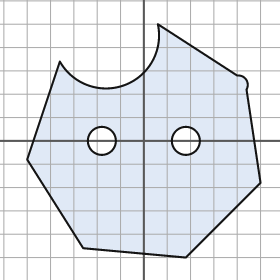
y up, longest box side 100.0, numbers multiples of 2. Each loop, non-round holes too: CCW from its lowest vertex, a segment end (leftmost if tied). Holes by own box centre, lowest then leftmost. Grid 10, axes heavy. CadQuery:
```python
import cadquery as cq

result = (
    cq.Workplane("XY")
    .moveTo(18.0, -50.0)
    .lineTo(50.0, -18.0)
    .lineTo(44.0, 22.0)
    .threePointArc((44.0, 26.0), (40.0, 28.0))
    .lineTo(6.0, 50.0)
    .threePointArc((-8.0, 24.0), (-36.0, 34.0))
    .lineTo(-50.0, -8.0)
    .lineTo(-26.0, -46.0)
    .close()
    .moveTo(-18.0, 0.0)
    .circle(6.0)
    .moveTo(18.0, 0.0)
    .circle(6.0)
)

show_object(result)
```